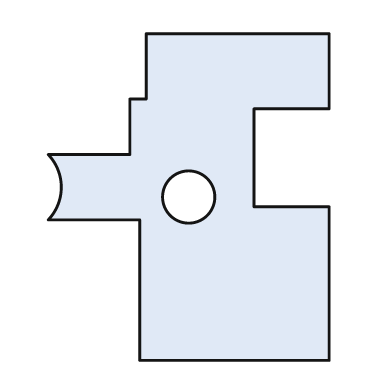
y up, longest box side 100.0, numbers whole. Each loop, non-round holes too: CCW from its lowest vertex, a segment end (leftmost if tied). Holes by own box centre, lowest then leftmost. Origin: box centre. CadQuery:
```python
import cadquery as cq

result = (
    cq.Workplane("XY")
    .moveTo(-15.0, -50.0)
    .lineTo(43.0, -50.0)
    .lineTo(43.0, -3.0)
    .lineTo(20.0, -3.0)
    .lineTo(20.0, 27.0)
    .lineTo(43.0, 27.0)
    .lineTo(43.0, 50.0)
    .lineTo(-13.0, 50.0)
    .lineTo(-13.0, 30.0)
    .lineTo(-18.0, 30.0)
    .lineTo(-18.0, 13.0)
    .lineTo(-43.0, 13.0)
    .threePointArc((-39.0, 3.0), (-43.0, -7.0))
    .lineTo(-15.0, -7.0)
    .close()
    .moveTo(0.0, 0.0)
    .circle(8.0)
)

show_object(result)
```